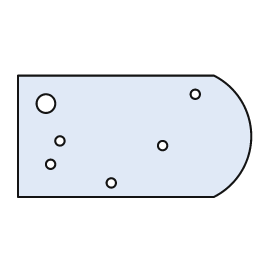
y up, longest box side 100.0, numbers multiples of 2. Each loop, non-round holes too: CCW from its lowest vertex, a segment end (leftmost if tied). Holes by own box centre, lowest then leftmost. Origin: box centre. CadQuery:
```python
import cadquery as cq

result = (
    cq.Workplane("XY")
    .moveTo(-50.0, -26.0)
    .lineTo(34.0, -26.0)
    .threePointArc((50.0, 0.0), (34.0, 26.0))
    .lineTo(-50.0, 26.0)
    .close()
    .moveTo(-10.0, -20.0)
    .circle(2.0)
    .moveTo(-36.0, -12.0)
    .circle(2.0)
    .moveTo(12.0, -4.0)
    .circle(2.0)
    .moveTo(-32.0, -2.0)
    .circle(2.0)
    .moveTo(-38.0, 14.0)
    .circle(4.0)
    .moveTo(26.0, 18.0)
    .circle(2.0)
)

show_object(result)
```